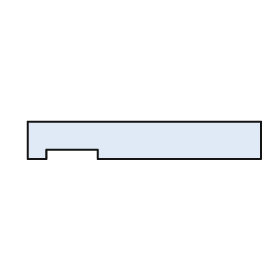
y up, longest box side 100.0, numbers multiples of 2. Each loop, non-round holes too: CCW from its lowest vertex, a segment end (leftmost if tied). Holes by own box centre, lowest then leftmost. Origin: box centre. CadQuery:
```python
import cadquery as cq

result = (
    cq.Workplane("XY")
    .moveTo(-50.0, -8.0)
    .lineTo(-42.0, -8.0)
    .lineTo(-42.0, -4.0)
    .lineTo(-20.0, -4.0)
    .lineTo(-20.0, -8.0)
    .lineTo(50.0, -8.0)
    .lineTo(50.0, 8.0)
    .lineTo(-50.0, 8.0)
    .close()
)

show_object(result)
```